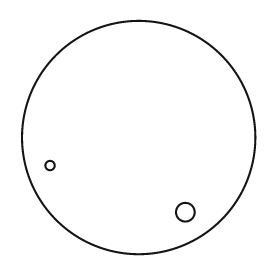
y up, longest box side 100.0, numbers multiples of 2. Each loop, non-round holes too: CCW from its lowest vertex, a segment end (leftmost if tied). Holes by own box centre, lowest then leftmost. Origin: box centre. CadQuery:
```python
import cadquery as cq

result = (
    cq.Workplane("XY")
    .moveTo(0.0, 0.0)
    .circle(50.0)
    .moveTo(20.0, -32.0)
    .circle(4.0)
    .moveTo(-38.0, -12.0)
    .circle(2.0)
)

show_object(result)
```